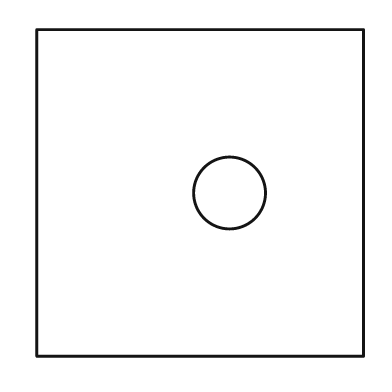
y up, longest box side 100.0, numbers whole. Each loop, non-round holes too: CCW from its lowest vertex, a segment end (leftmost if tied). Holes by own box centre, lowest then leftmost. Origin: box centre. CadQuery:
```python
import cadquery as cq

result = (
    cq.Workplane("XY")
    .moveTo(-50.0, -50.0)
    .lineTo(50.0, -50.0)
    .lineTo(50.0, 50.0)
    .lineTo(-50.0, 50.0)
    .close()
    .moveTo(9.0, 0.0)
    .circle(11.0)
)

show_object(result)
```